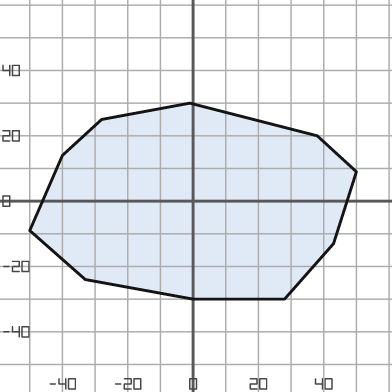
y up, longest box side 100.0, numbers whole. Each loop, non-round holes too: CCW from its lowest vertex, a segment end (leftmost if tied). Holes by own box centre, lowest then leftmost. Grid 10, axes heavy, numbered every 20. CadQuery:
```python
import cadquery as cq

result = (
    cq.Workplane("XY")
    .moveTo(0.0, -30.0)
    .lineTo(28.0, -30.0)
    .lineTo(43.0, -13.0)
    .lineTo(50.0, 9.0)
    .lineTo(38.0, 20.0)
    .lineTo(-1.0, 30.0)
    .lineTo(-28.0, 25.0)
    .lineTo(-40.0, 14.0)
    .lineTo(-50.0, -9.0)
    .lineTo(-33.0, -24.0)
    .close()
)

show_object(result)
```